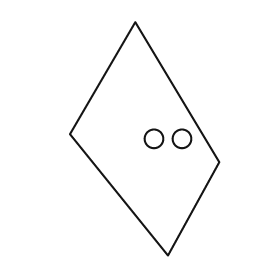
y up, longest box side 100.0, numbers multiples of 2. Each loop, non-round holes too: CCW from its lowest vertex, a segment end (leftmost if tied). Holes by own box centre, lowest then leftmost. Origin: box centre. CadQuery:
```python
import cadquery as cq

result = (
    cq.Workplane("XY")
    .moveTo(10.0, -50.0)
    .lineTo(32.0, -10.0)
    .lineTo(-4.0, 50.0)
    .lineTo(-32.0, 2.0)
    .close()
    .moveTo(4.0, 0.0)
    .circle(4.0)
    .moveTo(16.0, 0.0)
    .circle(4.0)
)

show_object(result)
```